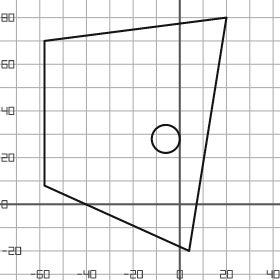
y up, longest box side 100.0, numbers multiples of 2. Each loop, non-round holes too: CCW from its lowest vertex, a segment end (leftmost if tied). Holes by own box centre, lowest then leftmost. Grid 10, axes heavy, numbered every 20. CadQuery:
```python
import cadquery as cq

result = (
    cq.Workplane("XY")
    .moveTo(4.0, -20.0)
    .lineTo(20.0, 80.0)
    .lineTo(-58.0, 70.0)
    .lineTo(-58.0, 8.0)
    .close()
    .moveTo(-6.0, 28.0)
    .circle(6.0)
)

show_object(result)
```